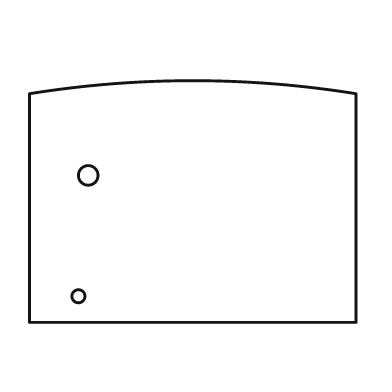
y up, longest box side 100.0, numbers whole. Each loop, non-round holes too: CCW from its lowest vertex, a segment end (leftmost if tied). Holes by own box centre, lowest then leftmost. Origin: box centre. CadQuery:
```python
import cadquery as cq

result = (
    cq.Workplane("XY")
    .moveTo(-50.0, -37.0)
    .lineTo(50.0, -37.0)
    .lineTo(50.0, 33.0)
    .threePointArc((0.0, 37.0), (-50.0, 33.0))
    .close()
    .moveTo(-35.0, -29.0)
    .circle(2.0)
    .moveTo(-32.0, 8.0)
    .circle(3.0)
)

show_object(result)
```